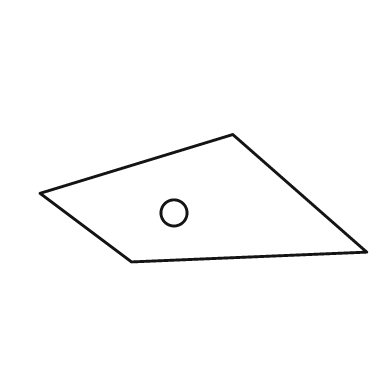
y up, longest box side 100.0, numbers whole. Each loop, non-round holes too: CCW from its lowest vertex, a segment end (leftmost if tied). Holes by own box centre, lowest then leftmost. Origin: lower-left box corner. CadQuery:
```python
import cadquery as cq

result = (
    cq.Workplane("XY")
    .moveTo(28.0, 0.0)
    .lineTo(100.0, 3.0)
    .lineTo(59.0, 39.0)
    .lineTo(0.0, 21.0)
    .close()
    .moveTo(41.0, 15.0)
    .circle(4.0)
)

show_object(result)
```